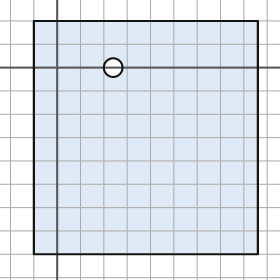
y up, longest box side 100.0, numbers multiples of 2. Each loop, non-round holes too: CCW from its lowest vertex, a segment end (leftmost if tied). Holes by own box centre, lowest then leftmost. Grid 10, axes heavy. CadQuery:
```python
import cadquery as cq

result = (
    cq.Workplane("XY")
    .moveTo(-10.0, -80.0)
    .lineTo(86.0, -80.0)
    .lineTo(86.0, 20.0)
    .lineTo(-10.0, 20.0)
    .close()
    .moveTo(24.0, 0.0)
    .circle(4.0)
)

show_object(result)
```